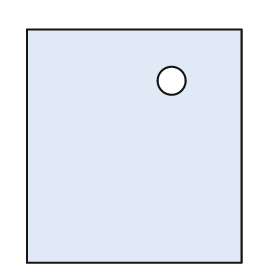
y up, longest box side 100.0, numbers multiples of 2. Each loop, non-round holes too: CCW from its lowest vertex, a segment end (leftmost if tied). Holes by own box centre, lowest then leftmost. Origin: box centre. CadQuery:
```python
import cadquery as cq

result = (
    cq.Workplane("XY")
    .moveTo(-46.0, -50.0)
    .lineTo(46.0, -50.0)
    .lineTo(46.0, 50.0)
    .lineTo(-46.0, 50.0)
    .close()
    .moveTo(16.0, 28.0)
    .circle(6.0)
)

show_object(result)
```